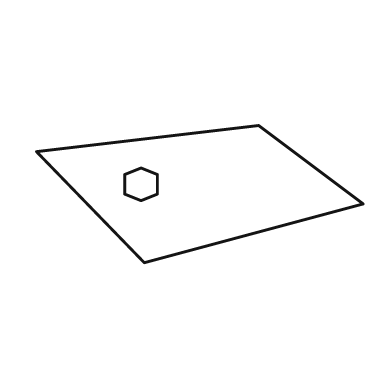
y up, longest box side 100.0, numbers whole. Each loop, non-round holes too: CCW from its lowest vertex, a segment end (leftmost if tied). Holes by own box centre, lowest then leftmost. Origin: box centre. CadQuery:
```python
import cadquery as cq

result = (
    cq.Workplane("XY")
    .moveTo(-17.0, -21.0)
    .lineTo(50.0, -3.0)
    .lineTo(18.0, 21.0)
    .lineTo(-50.0, 13.0)
    .close()
    .moveTo(-18.0, -2.0)
    .lineTo(-13.0, 0.0)
    .lineTo(-13.0, 6.0)
    .lineTo(-18.0, 8.0)
    .lineTo(-23.0, 6.0)
    .lineTo(-23.0, 0.0)
    .close()
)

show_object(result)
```